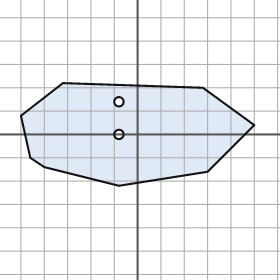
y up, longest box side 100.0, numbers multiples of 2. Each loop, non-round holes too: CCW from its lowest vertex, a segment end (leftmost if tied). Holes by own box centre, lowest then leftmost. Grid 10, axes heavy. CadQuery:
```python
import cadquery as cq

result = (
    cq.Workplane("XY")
    .moveTo(-8.0, -22.0)
    .lineTo(30.0, -16.0)
    .lineTo(50.0, 4.0)
    .lineTo(28.0, 20.0)
    .lineTo(-32.0, 22.0)
    .lineTo(-50.0, 8.0)
    .lineTo(-46.0, -10.0)
    .lineTo(-40.0, -14.0)
    .close()
    .moveTo(-8.0, 0.0)
    .circle(2.0)
    .moveTo(-8.0, 14.0)
    .circle(2.0)
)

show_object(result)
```